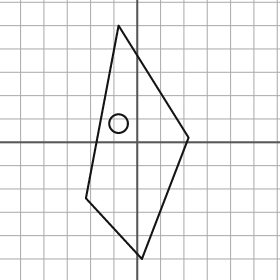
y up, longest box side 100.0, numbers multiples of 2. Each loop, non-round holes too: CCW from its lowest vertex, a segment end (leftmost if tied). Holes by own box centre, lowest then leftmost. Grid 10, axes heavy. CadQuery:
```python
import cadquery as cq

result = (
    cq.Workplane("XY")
    .moveTo(2.0, -50.0)
    .lineTo(22.0, 2.0)
    .lineTo(-8.0, 50.0)
    .lineTo(-22.0, -24.0)
    .close()
    .moveTo(-8.0, 8.0)
    .circle(4.0)
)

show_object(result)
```